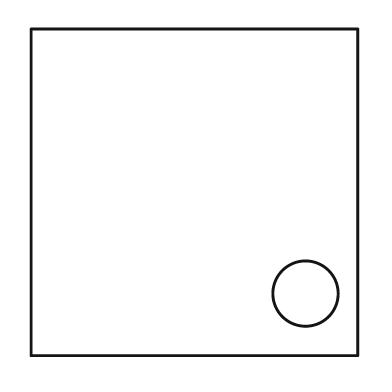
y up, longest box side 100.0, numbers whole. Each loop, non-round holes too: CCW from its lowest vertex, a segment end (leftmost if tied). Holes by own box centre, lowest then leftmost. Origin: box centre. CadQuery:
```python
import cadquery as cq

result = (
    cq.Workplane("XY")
    .moveTo(-50.0, -50.0)
    .lineTo(50.0, -50.0)
    .lineTo(50.0, 50.0)
    .lineTo(-50.0, 50.0)
    .close()
    .moveTo(34.0, -31.0)
    .circle(10.0)
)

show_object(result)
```